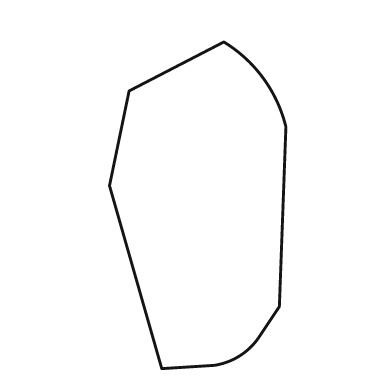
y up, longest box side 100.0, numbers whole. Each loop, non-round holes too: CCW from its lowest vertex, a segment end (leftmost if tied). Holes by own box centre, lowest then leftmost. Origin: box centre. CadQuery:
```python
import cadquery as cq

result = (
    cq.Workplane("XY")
    .moveTo(-11.0, -50.0)
    .lineTo(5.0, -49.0)
    .threePointArc((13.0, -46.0), (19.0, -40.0))
    .lineTo(25.0, -31.0)
    .lineTo(27.0, 24.0)
    .threePointArc((20.0, 39.0), (8.0, 50.0))
    .lineTo(-21.0, 35.0)
    .lineTo(-27.0, 6.0)
    .close()
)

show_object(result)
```